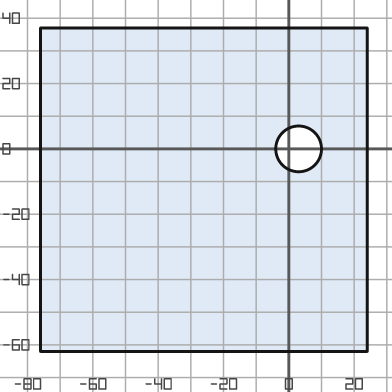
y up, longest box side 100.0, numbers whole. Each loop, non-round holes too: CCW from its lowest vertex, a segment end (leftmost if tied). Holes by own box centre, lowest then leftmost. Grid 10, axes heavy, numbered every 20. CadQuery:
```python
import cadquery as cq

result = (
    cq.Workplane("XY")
    .moveTo(-76.0, -62.0)
    .lineTo(24.0, -62.0)
    .lineTo(24.0, 37.0)
    .lineTo(-76.0, 37.0)
    .close()
    .moveTo(3.0, 0.0)
    .circle(7.0)
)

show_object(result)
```